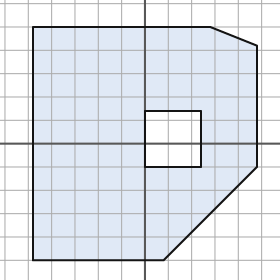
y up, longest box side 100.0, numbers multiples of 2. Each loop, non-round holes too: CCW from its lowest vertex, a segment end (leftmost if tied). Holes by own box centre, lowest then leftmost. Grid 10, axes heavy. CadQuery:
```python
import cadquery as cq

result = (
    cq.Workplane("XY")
    .moveTo(-48.0, -50.0)
    .lineTo(8.0, -50.0)
    .lineTo(48.0, -10.0)
    .lineTo(48.0, 42.0)
    .lineTo(28.0, 50.0)
    .lineTo(-48.0, 50.0)
    .close()
    .moveTo(0.0, -10.0)
    .lineTo(24.0, -10.0)
    .lineTo(24.0, 14.0)
    .lineTo(0.0, 14.0)
    .close()
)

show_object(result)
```